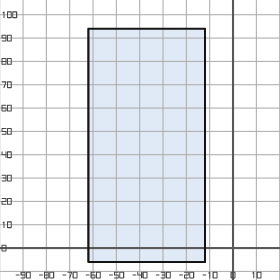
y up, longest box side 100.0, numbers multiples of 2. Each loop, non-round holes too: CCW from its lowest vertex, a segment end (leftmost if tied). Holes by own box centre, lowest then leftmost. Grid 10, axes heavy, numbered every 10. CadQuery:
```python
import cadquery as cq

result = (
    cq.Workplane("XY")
    .moveTo(-62.0, -6.0)
    .lineTo(-12.0, -6.0)
    .lineTo(-12.0, 94.0)
    .lineTo(-62.0, 94.0)
    .close()
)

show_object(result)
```